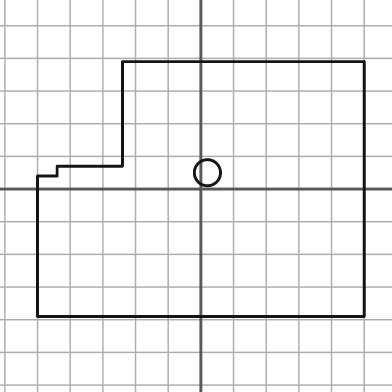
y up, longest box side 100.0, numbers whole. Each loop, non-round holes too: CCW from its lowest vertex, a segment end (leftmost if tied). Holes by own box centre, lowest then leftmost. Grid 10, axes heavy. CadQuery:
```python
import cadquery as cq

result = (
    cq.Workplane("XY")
    .moveTo(-50.0, -39.0)
    .lineTo(50.0, -39.0)
    .lineTo(50.0, 39.0)
    .lineTo(-24.0, 39.0)
    .lineTo(-24.0, 7.0)
    .lineTo(-44.0, 7.0)
    .lineTo(-44.0, 4.0)
    .lineTo(-50.0, 4.0)
    .close()
    .moveTo(2.0, 5.0)
    .circle(4.0)
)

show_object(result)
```